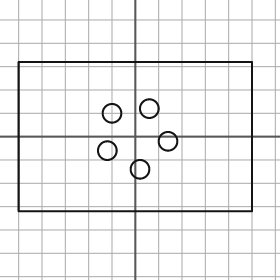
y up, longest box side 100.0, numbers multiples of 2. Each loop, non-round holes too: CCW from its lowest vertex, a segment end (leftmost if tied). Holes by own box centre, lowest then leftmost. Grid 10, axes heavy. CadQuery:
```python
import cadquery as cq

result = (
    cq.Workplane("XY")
    .moveTo(-50.0, -32.0)
    .lineTo(50.0, -32.0)
    .lineTo(50.0, 32.0)
    .lineTo(-50.0, 32.0)
    .close()
    .moveTo(2.0, -14.0)
    .circle(4.0)
    .moveTo(-12.0, -6.0)
    .circle(4.0)
    .moveTo(14.0, -2.0)
    .circle(4.0)
    .moveTo(-10.0, 10.0)
    .circle(4.0)
    .moveTo(6.0, 12.0)
    .circle(4.0)
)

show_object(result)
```